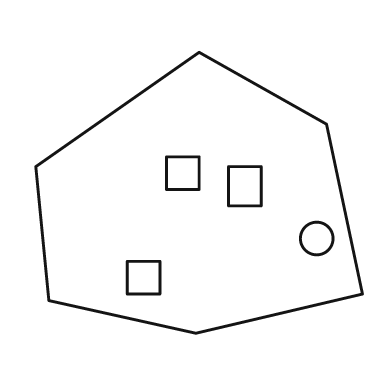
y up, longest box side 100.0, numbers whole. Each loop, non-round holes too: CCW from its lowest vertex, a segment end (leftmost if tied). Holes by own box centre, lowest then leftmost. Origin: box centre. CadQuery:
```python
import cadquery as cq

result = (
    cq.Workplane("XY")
    .moveTo(-1.0, -43.0)
    .lineTo(50.0, -31.0)
    .lineTo(39.0, 21.0)
    .lineTo(0.0, 43.0)
    .lineTo(-50.0, 8.0)
    .lineTo(-46.0, -33.0)
    .close()
    .moveTo(-22.0, -31.0)
    .lineTo(-12.0, -31.0)
    .lineTo(-12.0, -21.0)
    .lineTo(-22.0, -21.0)
    .close()
    .moveTo(36.0, -14.0)
    .circle(5.0)
    .moveTo(9.0, -4.0)
    .lineTo(19.0, -4.0)
    .lineTo(19.0, 8.0)
    .lineTo(9.0, 8.0)
    .close()
    .moveTo(-10.0, 1.0)
    .lineTo(0.0, 1.0)
    .lineTo(0.0, 11.0)
    .lineTo(-10.0, 11.0)
    .close()
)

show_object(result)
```